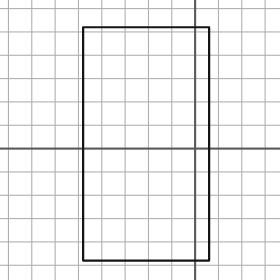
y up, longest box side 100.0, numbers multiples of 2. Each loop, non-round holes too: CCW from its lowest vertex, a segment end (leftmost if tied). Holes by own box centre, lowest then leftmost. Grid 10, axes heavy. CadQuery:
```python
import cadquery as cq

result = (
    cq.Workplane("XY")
    .moveTo(-48.0, -48.0)
    .lineTo(6.0, -48.0)
    .lineTo(6.0, 52.0)
    .lineTo(-48.0, 52.0)
    .close()
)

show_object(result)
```